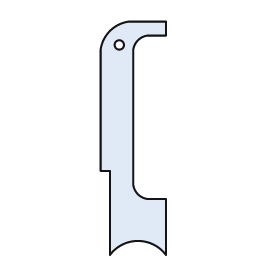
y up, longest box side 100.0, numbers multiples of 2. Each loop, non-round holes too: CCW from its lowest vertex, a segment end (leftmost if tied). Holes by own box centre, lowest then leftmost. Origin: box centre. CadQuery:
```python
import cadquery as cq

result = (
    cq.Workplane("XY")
    .moveTo(-10.0, -50.0)
    .threePointArc((2.0, -44.0), (14.0, -50.0))
    .lineTo(14.0, -26.0)
    .lineTo(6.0, -26.0)
    .threePointArc((2.0, -24.0), (0.0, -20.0))
    .lineTo(0.0, 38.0)
    .threePointArc((2.0, 42.0), (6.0, 44.0))
    .lineTo(14.0, 44.0)
    .lineTo(14.0, 50.0)
    .lineTo(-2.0, 50.0)
    .threePointArc((-10.0, 46.0), (-14.0, 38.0))
    .lineTo(-14.0, -14.0)
    .lineTo(-10.0, -14.0)
    .close()
    .moveTo(-6.0, 40.0)
    .circle(2.0)
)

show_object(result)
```